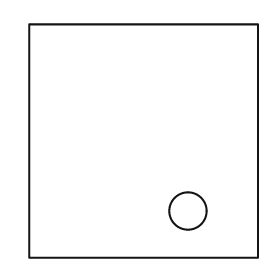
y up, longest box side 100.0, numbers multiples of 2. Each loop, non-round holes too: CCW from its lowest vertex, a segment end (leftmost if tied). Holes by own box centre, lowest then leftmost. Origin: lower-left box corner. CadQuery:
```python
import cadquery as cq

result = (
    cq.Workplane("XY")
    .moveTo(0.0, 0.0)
    .lineTo(98.0, 0.0)
    .lineTo(98.0, 100.0)
    .lineTo(0.0, 100.0)
    .close()
    .moveTo(68.0, 20.0)
    .circle(8.0)
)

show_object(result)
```